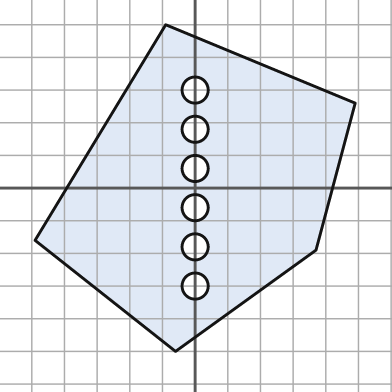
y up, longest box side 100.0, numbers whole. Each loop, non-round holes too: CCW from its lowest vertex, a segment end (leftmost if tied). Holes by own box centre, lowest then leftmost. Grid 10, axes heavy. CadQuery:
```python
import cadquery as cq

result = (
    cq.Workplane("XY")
    .moveTo(-6.0, -50.0)
    .lineTo(37.0, -19.0)
    .lineTo(49.0, 26.0)
    .lineTo(-9.0, 50.0)
    .lineTo(-49.0, -16.0)
    .close()
    .moveTo(0.0, -30.0)
    .circle(4.0)
    .moveTo(0.0, -18.0)
    .circle(4.0)
    .moveTo(0.0, -6.0)
    .circle(4.0)
    .moveTo(0.0, 6.0)
    .circle(4.0)
    .moveTo(0.0, 18.0)
    .circle(4.0)
    .moveTo(0.0, 30.0)
    .circle(4.0)
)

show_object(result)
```